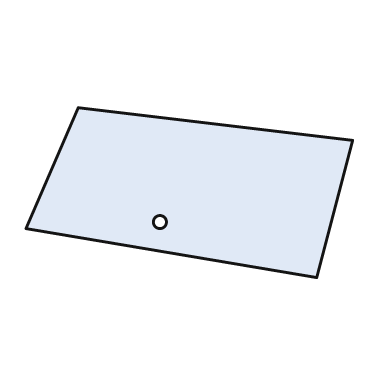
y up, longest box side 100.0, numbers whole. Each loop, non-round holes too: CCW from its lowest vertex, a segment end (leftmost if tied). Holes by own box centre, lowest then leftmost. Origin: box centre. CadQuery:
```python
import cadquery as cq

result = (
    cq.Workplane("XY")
    .moveTo(39.0, -26.0)
    .lineTo(50.0, 16.0)
    .lineTo(-34.0, 26.0)
    .lineTo(-50.0, -11.0)
    .close()
    .moveTo(-9.0, -9.0)
    .circle(2.0)
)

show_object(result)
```